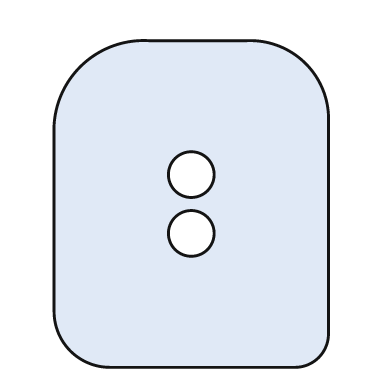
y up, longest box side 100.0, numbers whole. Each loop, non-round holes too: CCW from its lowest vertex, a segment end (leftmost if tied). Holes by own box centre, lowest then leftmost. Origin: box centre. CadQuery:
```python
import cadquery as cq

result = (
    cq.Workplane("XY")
    .moveTo(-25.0, -50.0)
    .lineTo(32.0, -50.0)
    .threePointArc((39.0, -47.0), (42.0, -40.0))
    .lineTo(42.0, 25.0)
    .threePointArc((35.0, 43.0), (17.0, 50.0))
    .lineTo(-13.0, 50.0)
    .threePointArc((-34.0, 42.0), (-42.0, 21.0))
    .lineTo(-42.0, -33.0)
    .threePointArc((-37.0, -45.0), (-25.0, -50.0))
    .close()
    .moveTo(0.0, -9.0)
    .circle(7.0)
    .moveTo(0.0, 9.0)
    .circle(7.0)
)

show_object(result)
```